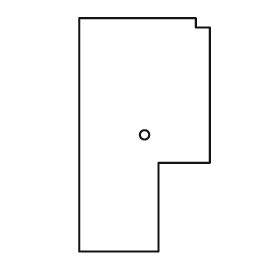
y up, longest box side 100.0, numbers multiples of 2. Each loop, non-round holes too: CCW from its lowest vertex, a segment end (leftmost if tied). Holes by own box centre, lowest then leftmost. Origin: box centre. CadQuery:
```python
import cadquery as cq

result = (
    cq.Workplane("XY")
    .moveTo(-28.0, -50.0)
    .lineTo(6.0, -50.0)
    .lineTo(6.0, -12.0)
    .lineTo(28.0, -12.0)
    .lineTo(28.0, 46.0)
    .lineTo(22.0, 46.0)
    .lineTo(22.0, 50.0)
    .lineTo(-28.0, 50.0)
    .close()
    .moveTo(0.0, 0.0)
    .circle(2.0)
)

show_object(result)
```